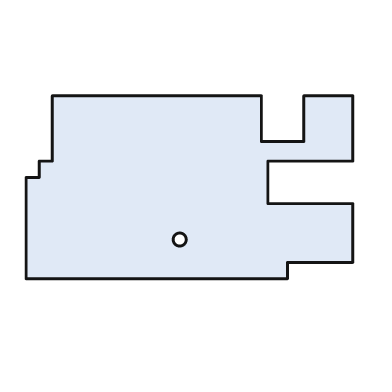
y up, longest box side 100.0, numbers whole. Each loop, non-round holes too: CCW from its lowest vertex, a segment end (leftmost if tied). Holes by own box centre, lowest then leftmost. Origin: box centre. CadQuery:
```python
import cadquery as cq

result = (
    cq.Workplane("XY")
    .moveTo(-50.0, -28.0)
    .lineTo(30.0, -28.0)
    .lineTo(30.0, -23.0)
    .lineTo(50.0, -23.0)
    .lineTo(50.0, -5.0)
    .lineTo(24.0, -5.0)
    .lineTo(24.0, 8.0)
    .lineTo(50.0, 8.0)
    .lineTo(50.0, 28.0)
    .lineTo(35.0, 28.0)
    .lineTo(35.0, 14.0)
    .lineTo(22.0, 14.0)
    .lineTo(22.0, 28.0)
    .lineTo(-42.0, 28.0)
    .lineTo(-42.0, 8.0)
    .lineTo(-46.0, 8.0)
    .lineTo(-46.0, 3.0)
    .lineTo(-50.0, 3.0)
    .close()
    .moveTo(-3.0, -16.0)
    .circle(2.0)
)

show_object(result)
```